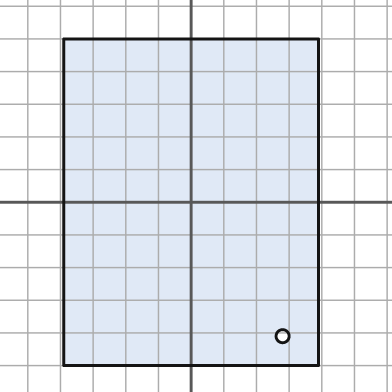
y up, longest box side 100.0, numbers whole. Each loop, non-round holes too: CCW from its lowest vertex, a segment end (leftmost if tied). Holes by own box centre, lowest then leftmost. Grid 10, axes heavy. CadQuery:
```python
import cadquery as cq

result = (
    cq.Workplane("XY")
    .moveTo(-39.0, -50.0)
    .lineTo(39.0, -50.0)
    .lineTo(39.0, 50.0)
    .lineTo(-39.0, 50.0)
    .close()
    .moveTo(28.0, -41.0)
    .circle(2.0)
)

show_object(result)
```